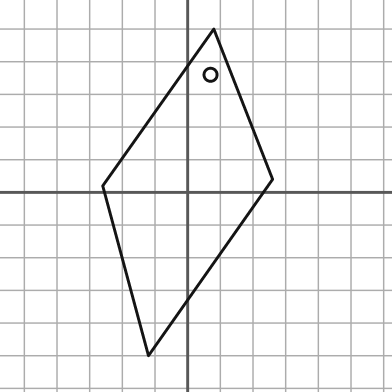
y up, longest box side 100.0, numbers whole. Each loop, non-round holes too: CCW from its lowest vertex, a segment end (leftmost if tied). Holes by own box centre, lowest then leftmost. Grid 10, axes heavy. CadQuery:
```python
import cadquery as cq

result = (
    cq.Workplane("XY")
    .moveTo(-12.0, -50.0)
    .lineTo(26.0, 4.0)
    .lineTo(8.0, 50.0)
    .lineTo(-26.0, 2.0)
    .close()
    .moveTo(7.0, 36.0)
    .circle(2.0)
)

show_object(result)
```